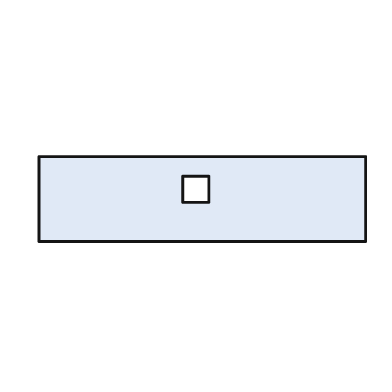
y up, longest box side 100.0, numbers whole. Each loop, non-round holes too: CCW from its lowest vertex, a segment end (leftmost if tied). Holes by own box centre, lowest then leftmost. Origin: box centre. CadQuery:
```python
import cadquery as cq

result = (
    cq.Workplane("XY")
    .moveTo(-50.0, -13.0)
    .lineTo(50.0, -13.0)
    .lineTo(50.0, 13.0)
    .lineTo(-50.0, 13.0)
    .close()
    .moveTo(-6.0, -1.0)
    .lineTo(2.0, -1.0)
    .lineTo(2.0, 7.0)
    .lineTo(-6.0, 7.0)
    .close()
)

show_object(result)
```